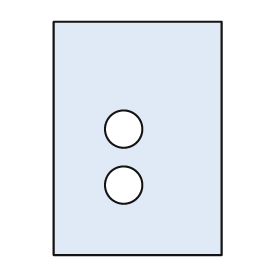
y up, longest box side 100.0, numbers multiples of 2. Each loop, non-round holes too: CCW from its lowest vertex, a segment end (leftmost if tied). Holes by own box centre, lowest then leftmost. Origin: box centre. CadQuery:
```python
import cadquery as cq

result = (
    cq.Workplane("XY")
    .moveTo(-36.0, -50.0)
    .lineTo(36.0, -50.0)
    .lineTo(36.0, 50.0)
    .lineTo(-36.0, 50.0)
    .close()
    .moveTo(-6.0, -20.0)
    .circle(8.0)
    .moveTo(-6.0, 4.0)
    .circle(8.0)
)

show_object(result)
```